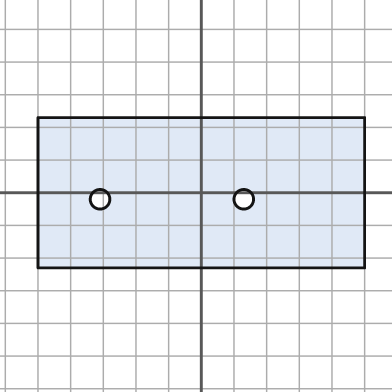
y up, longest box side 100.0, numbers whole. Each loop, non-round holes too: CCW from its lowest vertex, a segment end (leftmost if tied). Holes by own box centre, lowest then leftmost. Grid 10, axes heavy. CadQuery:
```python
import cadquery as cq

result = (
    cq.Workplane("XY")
    .moveTo(-50.0, -23.0)
    .lineTo(50.0, -23.0)
    .lineTo(50.0, 23.0)
    .lineTo(-50.0, 23.0)
    .close()
    .moveTo(-31.0, -2.0)
    .circle(3.0)
    .moveTo(13.0, -2.0)
    .circle(3.0)
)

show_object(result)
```